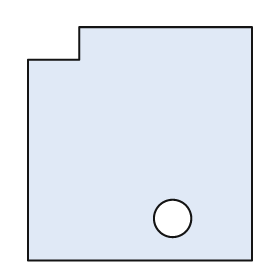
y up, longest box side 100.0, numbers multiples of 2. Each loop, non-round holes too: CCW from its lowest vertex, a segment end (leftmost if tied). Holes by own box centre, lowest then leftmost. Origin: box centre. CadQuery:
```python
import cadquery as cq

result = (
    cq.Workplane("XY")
    .moveTo(-48.0, -50.0)
    .lineTo(48.0, -50.0)
    .lineTo(48.0, 50.0)
    .lineTo(-26.0, 50.0)
    .lineTo(-26.0, 36.0)
    .lineTo(-48.0, 36.0)
    .close()
    .moveTo(14.0, -32.0)
    .circle(8.0)
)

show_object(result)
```